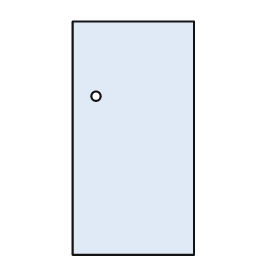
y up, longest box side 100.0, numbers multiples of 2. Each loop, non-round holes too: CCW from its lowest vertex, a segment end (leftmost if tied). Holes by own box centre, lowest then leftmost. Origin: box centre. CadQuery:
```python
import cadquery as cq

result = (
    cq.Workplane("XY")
    .moveTo(-26.0, -50.0)
    .lineTo(26.0, -50.0)
    .lineTo(26.0, 50.0)
    .lineTo(-26.0, 50.0)
    .close()
    .moveTo(-16.0, 18.0)
    .circle(2.0)
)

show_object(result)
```